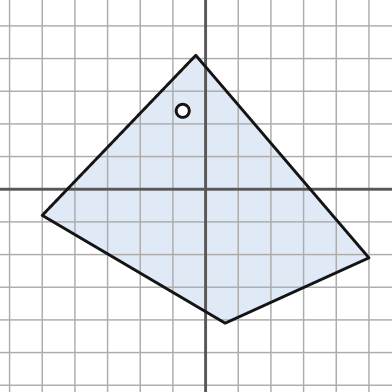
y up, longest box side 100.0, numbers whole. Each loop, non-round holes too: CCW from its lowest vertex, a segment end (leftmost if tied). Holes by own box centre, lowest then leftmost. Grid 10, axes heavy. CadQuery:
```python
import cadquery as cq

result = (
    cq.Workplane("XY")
    .moveTo(6.0, -41.0)
    .lineTo(50.0, -21.0)
    .lineTo(-3.0, 41.0)
    .lineTo(-50.0, -8.0)
    .close()
    .moveTo(-7.0, 24.0)
    .circle(2.0)
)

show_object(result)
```